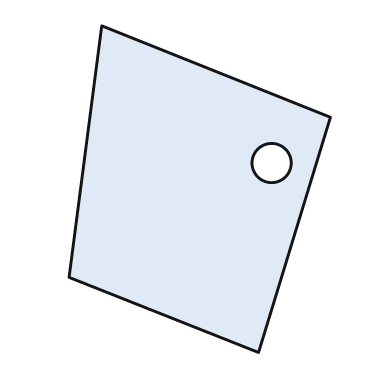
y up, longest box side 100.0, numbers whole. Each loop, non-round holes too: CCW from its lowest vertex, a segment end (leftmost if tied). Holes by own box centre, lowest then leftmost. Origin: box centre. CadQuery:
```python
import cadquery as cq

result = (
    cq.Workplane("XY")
    .moveTo(18.0, -50.0)
    .lineTo(40.0, 22.0)
    .lineTo(-30.0, 50.0)
    .lineTo(-40.0, -27.0)
    .close()
    .moveTo(22.0, 8.0)
    .circle(6.0)
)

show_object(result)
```